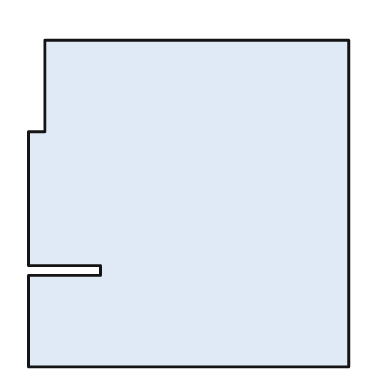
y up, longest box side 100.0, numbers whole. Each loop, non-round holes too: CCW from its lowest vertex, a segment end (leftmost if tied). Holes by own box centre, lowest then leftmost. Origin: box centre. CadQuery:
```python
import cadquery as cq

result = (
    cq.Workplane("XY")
    .moveTo(-49.0, -50.0)
    .lineTo(49.0, -50.0)
    .lineTo(49.0, 50.0)
    .lineTo(-44.0, 50.0)
    .lineTo(-44.0, 22.0)
    .lineTo(-49.0, 22.0)
    .lineTo(-49.0, -19.0)
    .lineTo(-27.0, -19.0)
    .lineTo(-27.0, -22.0)
    .lineTo(-49.0, -22.0)
    .close()
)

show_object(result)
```